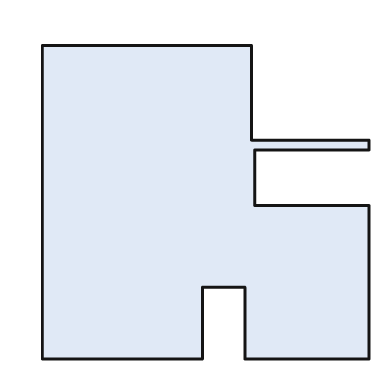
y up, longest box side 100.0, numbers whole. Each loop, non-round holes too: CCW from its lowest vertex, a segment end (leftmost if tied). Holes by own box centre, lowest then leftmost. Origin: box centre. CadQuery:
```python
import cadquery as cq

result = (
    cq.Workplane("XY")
    .moveTo(-50.0, -48.0)
    .lineTo(-1.0, -48.0)
    .lineTo(-1.0, -26.0)
    .lineTo(12.0, -26.0)
    .lineTo(12.0, -48.0)
    .lineTo(50.0, -48.0)
    .lineTo(50.0, -1.0)
    .lineTo(15.0, -1.0)
    .lineTo(15.0, 16.0)
    .lineTo(50.0, 16.0)
    .lineTo(50.0, 19.0)
    .lineTo(14.0, 19.0)
    .lineTo(14.0, 48.0)
    .lineTo(-50.0, 48.0)
    .close()
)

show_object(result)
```